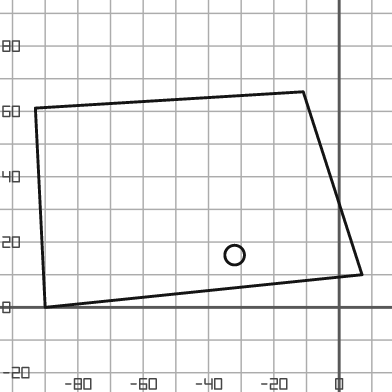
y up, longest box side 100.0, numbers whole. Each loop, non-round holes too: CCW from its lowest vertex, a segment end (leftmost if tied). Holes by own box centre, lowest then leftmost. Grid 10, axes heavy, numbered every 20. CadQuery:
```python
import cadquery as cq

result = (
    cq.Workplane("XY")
    .moveTo(-90.0, 0.0)
    .lineTo(7.0, 10.0)
    .lineTo(-11.0, 66.0)
    .lineTo(-93.0, 61.0)
    .close()
    .moveTo(-32.0, 16.0)
    .circle(3.0)
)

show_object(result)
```